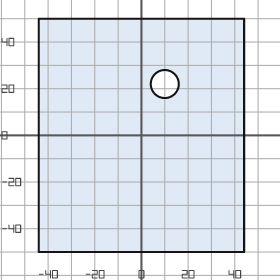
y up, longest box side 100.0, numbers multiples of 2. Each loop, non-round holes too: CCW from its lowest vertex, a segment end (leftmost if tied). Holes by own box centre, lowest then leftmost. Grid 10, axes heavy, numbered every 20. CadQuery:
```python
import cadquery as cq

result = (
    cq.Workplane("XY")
    .moveTo(-44.0, -50.0)
    .lineTo(44.0, -50.0)
    .lineTo(44.0, 50.0)
    .lineTo(-44.0, 50.0)
    .close()
    .moveTo(10.0, 22.0)
    .circle(6.0)
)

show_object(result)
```